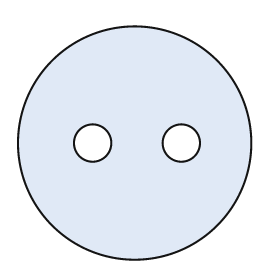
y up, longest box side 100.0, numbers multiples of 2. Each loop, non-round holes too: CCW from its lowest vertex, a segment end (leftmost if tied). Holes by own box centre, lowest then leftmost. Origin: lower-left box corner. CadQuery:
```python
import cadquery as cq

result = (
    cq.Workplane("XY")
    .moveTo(50.0, 50.0)
    .circle(50.0)
    .moveTo(32.0, 50.0)
    .circle(8.0)
    .moveTo(70.0, 50.0)
    .circle(8.0)
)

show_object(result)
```